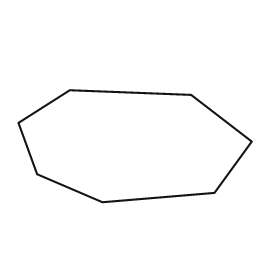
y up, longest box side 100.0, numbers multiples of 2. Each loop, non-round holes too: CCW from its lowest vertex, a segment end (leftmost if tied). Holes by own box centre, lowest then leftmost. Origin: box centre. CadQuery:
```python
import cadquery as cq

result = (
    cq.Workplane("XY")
    .moveTo(-14.0, -24.0)
    .lineTo(34.0, -20.0)
    .lineTo(50.0, 2.0)
    .lineTo(24.0, 22.0)
    .lineTo(-28.0, 24.0)
    .lineTo(-50.0, 10.0)
    .lineTo(-42.0, -12.0)
    .close()
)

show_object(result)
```